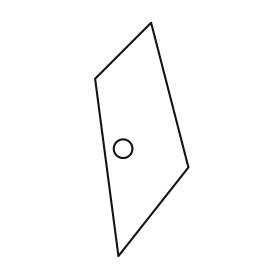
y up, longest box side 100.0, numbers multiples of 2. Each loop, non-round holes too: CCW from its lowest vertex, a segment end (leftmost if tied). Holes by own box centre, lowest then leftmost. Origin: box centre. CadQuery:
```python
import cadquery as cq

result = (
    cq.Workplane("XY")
    .moveTo(-10.0, -50.0)
    .lineTo(20.0, -12.0)
    .lineTo(4.0, 50.0)
    .lineTo(-20.0, 26.0)
    .close()
    .moveTo(-8.0, -4.0)
    .circle(4.0)
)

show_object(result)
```